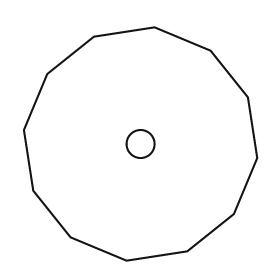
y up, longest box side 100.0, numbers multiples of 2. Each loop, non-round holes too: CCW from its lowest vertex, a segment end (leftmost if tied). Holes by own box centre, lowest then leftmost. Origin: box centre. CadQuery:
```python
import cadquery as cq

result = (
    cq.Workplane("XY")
    .moveTo(-6.0, -50.0)
    .lineTo(20.0, -46.0)
    .lineTo(40.0, -30.0)
    .lineTo(50.0, -6.0)
    .lineTo(46.0, 20.0)
    .lineTo(30.0, 40.0)
    .lineTo(6.0, 50.0)
    .lineTo(-20.0, 46.0)
    .lineTo(-40.0, 30.0)
    .lineTo(-50.0, 6.0)
    .lineTo(-46.0, -20.0)
    .lineTo(-30.0, -40.0)
    .close()
    .moveTo(0.0, 0.0)
    .circle(6.0)
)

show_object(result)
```